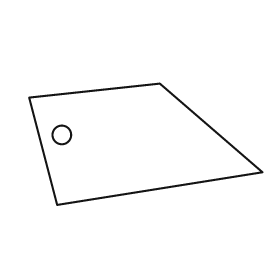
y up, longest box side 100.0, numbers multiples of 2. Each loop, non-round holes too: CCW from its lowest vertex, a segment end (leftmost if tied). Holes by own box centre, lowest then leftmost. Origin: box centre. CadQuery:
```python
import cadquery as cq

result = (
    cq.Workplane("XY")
    .moveTo(-38.0, -26.0)
    .lineTo(50.0, -12.0)
    .lineTo(6.0, 26.0)
    .lineTo(-50.0, 20.0)
    .close()
    .moveTo(-36.0, 4.0)
    .circle(4.0)
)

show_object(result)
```